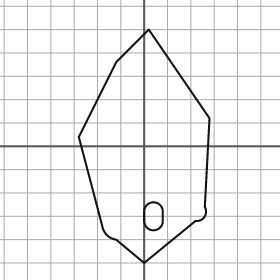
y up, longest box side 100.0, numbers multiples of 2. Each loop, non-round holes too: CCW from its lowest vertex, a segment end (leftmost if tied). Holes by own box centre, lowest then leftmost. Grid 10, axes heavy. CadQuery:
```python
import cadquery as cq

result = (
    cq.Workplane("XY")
    .moveTo(0.0, -50.0)
    .lineTo(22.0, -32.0)
    .threePointArc((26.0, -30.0), (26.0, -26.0))
    .lineTo(28.0, 12.0)
    .lineTo(2.0, 50.0)
    .lineTo(-12.0, 36.0)
    .lineTo(-28.0, 4.0)
    .lineTo(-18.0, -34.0)
    .threePointArc((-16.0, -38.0), (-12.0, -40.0))
    .close()
    .moveTo(0.0, -32.0)
    .threePointArc((4.0, -36.0), (8.0, -32.0))
    .lineTo(8.0, -28.0)
    .threePointArc((4.0, -24.0), (0.0, -28.0))
    .close()
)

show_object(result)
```